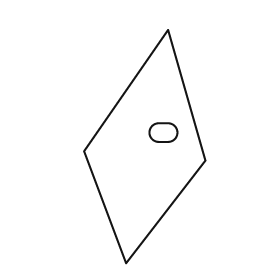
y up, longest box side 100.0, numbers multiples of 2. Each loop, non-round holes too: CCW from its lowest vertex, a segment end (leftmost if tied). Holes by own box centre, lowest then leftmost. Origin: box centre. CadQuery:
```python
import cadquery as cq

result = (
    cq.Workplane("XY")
    .moveTo(-8.0, -50.0)
    .lineTo(26.0, -6.0)
    .lineTo(10.0, 50.0)
    .lineTo(-26.0, -2.0)
    .close()
    .moveTo(6.0, 2.0)
    .lineTo(10.0, 2.0)
    .threePointArc((14.0, 6.0), (10.0, 10.0))
    .lineTo(6.0, 10.0)
    .threePointArc((2.0, 6.0), (6.0, 2.0))
    .close()
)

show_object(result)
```